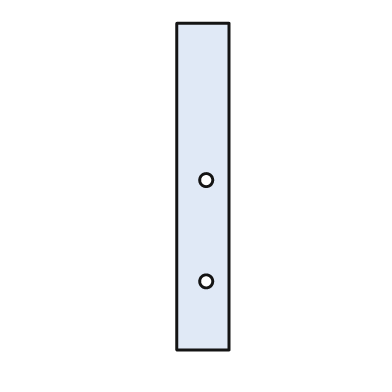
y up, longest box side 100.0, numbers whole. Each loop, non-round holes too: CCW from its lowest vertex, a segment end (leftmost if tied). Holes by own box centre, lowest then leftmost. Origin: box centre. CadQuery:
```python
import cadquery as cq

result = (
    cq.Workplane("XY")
    .moveTo(-8.0, -50.0)
    .lineTo(8.0, -50.0)
    .lineTo(8.0, 50.0)
    .lineTo(-8.0, 50.0)
    .close()
    .moveTo(1.0, -29.0)
    .circle(2.0)
    .moveTo(1.0, 2.0)
    .circle(2.0)
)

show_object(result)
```